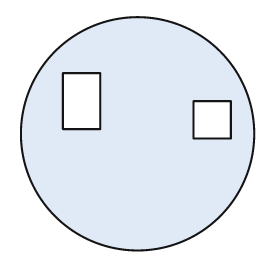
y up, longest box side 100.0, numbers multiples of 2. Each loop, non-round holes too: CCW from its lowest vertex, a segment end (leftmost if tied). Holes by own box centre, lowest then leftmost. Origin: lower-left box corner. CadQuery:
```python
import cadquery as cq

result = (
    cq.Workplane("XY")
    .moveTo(50.0, 50.0)
    .circle(50.0)
    .moveTo(74.0, 48.0)
    .lineTo(90.0, 48.0)
    .lineTo(90.0, 64.0)
    .lineTo(74.0, 64.0)
    .close()
    .moveTo(18.0, 52.0)
    .lineTo(34.0, 52.0)
    .lineTo(34.0, 76.0)
    .lineTo(18.0, 76.0)
    .close()
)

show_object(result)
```